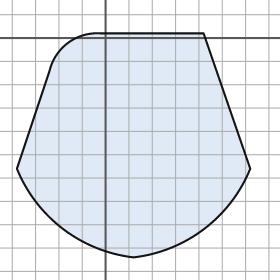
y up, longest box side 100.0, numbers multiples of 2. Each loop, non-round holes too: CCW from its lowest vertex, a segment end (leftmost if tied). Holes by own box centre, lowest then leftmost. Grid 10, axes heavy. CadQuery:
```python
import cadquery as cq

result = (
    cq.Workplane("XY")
    .moveTo(12.0, -94.0)
    .threePointArc((42.0, -82.0), (62.0, -56.0))
    .lineTo(42.0, 2.0)
    .lineTo(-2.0, 2.0)
    .threePointArc((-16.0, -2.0), (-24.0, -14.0))
    .lineTo(-38.0, -56.0)
    .threePointArc((-18.0, -82.0), (12.0, -94.0))
    .close()
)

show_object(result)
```